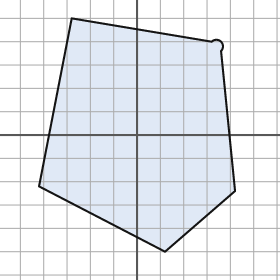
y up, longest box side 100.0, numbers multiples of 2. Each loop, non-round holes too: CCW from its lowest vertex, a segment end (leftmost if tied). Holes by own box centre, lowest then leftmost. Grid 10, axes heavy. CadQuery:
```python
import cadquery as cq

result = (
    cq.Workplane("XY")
    .moveTo(12.0, -50.0)
    .lineTo(42.0, -24.0)
    .lineTo(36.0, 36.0)
    .threePointArc((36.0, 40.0), (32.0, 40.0))
    .lineTo(-28.0, 50.0)
    .lineTo(-42.0, -22.0)
    .close()
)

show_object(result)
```